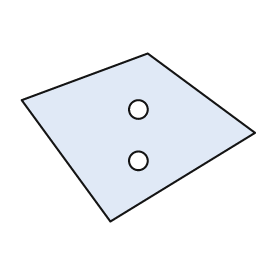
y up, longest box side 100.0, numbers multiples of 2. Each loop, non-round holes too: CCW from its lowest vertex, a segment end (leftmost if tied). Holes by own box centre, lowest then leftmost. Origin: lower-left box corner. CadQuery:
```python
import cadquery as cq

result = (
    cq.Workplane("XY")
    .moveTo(38.0, 0.0)
    .lineTo(100.0, 38.0)
    .lineTo(54.0, 72.0)
    .lineTo(0.0, 52.0)
    .close()
    .moveTo(50.0, 26.0)
    .circle(4.0)
    .moveTo(50.0, 48.0)
    .circle(4.0)
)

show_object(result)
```